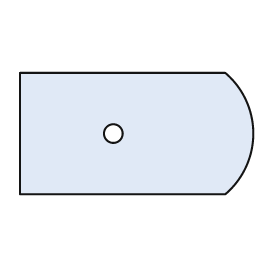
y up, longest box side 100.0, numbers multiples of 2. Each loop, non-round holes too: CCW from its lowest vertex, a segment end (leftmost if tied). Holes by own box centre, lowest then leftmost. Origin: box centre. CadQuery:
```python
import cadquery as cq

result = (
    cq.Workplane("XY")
    .moveTo(-50.0, -26.0)
    .lineTo(38.0, -26.0)
    .threePointArc((50.0, 0.0), (38.0, 26.0))
    .lineTo(-50.0, 26.0)
    .close()
    .moveTo(-10.0, 0.0)
    .circle(4.0)
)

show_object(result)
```